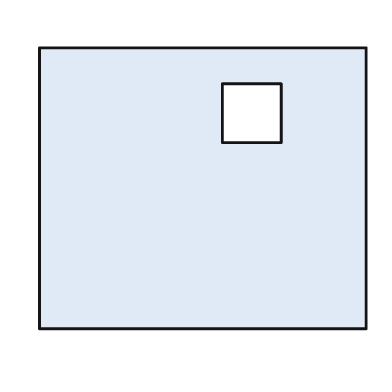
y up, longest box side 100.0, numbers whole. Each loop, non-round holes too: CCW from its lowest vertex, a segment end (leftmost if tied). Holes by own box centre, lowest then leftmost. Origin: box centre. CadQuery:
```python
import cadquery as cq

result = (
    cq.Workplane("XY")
    .moveTo(-50.0, -43.0)
    .lineTo(50.0, -43.0)
    .lineTo(50.0, 43.0)
    .lineTo(-50.0, 43.0)
    .close()
    .moveTo(6.0, 14.0)
    .lineTo(24.0, 14.0)
    .lineTo(24.0, 32.0)
    .lineTo(6.0, 32.0)
    .close()
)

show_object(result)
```